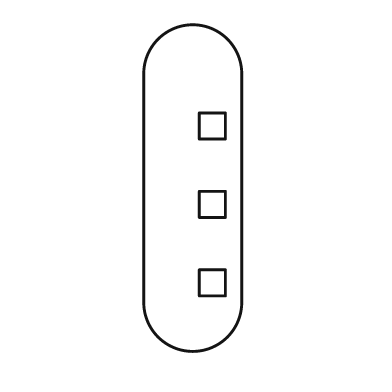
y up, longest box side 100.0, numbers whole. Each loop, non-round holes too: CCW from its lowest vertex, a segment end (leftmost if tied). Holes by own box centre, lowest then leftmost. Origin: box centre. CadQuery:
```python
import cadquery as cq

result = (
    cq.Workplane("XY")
    .moveTo(-15.0, -35.0)
    .threePointArc((0.0, -50.0), (15.0, -35.0))
    .lineTo(15.0, 35.0)
    .threePointArc((0.0, 50.0), (-15.0, 35.0))
    .close()
    .moveTo(2.0, -33.0)
    .lineTo(10.0, -33.0)
    .lineTo(10.0, -25.0)
    .lineTo(2.0, -25.0)
    .close()
    .moveTo(2.0, -9.0)
    .lineTo(10.0, -9.0)
    .lineTo(10.0, -1.0)
    .lineTo(2.0, -1.0)
    .close()
    .moveTo(2.0, 15.0)
    .lineTo(10.0, 15.0)
    .lineTo(10.0, 23.0)
    .lineTo(2.0, 23.0)
    .close()
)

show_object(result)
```